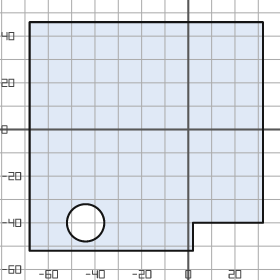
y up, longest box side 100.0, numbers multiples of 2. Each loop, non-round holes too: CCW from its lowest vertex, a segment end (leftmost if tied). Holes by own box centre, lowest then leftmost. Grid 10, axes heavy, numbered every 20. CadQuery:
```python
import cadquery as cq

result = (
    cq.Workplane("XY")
    .moveTo(-68.0, -52.0)
    .lineTo(2.0, -52.0)
    .lineTo(2.0, -40.0)
    .lineTo(32.0, -40.0)
    .lineTo(32.0, 46.0)
    .lineTo(-68.0, 46.0)
    .close()
    .moveTo(-44.0, -40.0)
    .circle(8.0)
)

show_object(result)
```